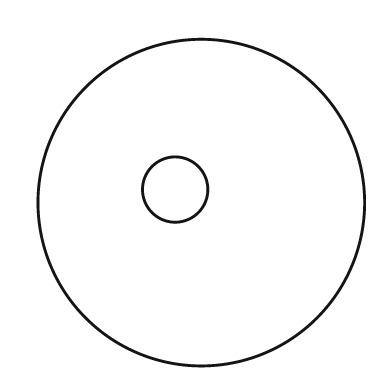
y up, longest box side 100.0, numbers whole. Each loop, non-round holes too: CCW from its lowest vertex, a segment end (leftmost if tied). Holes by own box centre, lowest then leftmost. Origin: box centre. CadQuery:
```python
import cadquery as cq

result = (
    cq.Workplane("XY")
    .moveTo(0.0, 0.0)
    .circle(50.0)
    .moveTo(-8.0, 4.0)
    .circle(10.0)
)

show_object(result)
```